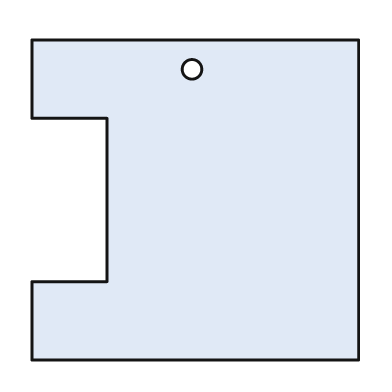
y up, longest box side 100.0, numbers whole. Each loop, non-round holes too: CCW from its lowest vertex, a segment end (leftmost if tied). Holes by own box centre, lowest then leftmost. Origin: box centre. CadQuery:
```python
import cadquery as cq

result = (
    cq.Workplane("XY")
    .moveTo(-50.0, -49.0)
    .lineTo(50.0, -49.0)
    .lineTo(50.0, 49.0)
    .lineTo(-50.0, 49.0)
    .lineTo(-50.0, 25.0)
    .lineTo(-27.0, 25.0)
    .lineTo(-27.0, -25.0)
    .lineTo(-50.0, -25.0)
    .close()
    .moveTo(-1.0, 40.0)
    .circle(3.0)
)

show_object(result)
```